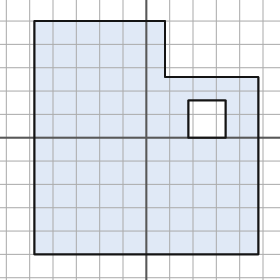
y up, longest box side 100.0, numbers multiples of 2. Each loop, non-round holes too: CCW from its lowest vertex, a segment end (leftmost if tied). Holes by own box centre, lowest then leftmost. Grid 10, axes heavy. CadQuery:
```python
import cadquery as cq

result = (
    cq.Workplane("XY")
    .moveTo(-48.0, -50.0)
    .lineTo(48.0, -50.0)
    .lineTo(48.0, 26.0)
    .lineTo(8.0, 26.0)
    .lineTo(8.0, 50.0)
    .lineTo(-48.0, 50.0)
    .close()
    .moveTo(18.0, 0.0)
    .lineTo(34.0, 0.0)
    .lineTo(34.0, 16.0)
    .lineTo(18.0, 16.0)
    .close()
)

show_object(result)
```